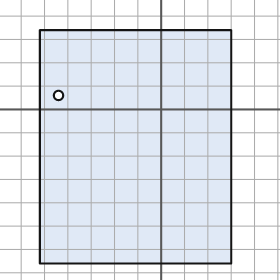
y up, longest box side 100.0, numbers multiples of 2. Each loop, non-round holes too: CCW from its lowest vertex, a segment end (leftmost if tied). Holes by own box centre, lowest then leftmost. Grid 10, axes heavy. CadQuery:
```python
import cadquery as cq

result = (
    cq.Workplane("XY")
    .moveTo(-52.0, -66.0)
    .lineTo(30.0, -66.0)
    .lineTo(30.0, 34.0)
    .lineTo(-52.0, 34.0)
    .close()
    .moveTo(-44.0, 6.0)
    .circle(2.0)
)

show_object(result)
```